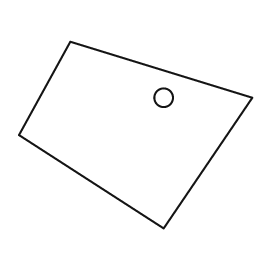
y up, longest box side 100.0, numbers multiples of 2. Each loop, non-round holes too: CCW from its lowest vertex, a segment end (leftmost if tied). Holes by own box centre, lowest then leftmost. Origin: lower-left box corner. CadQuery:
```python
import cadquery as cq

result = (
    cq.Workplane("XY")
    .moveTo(62.0, 0.0)
    .lineTo(100.0, 56.0)
    .lineTo(22.0, 80.0)
    .lineTo(0.0, 40.0)
    .close()
    .moveTo(62.0, 56.0)
    .circle(4.0)
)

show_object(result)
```